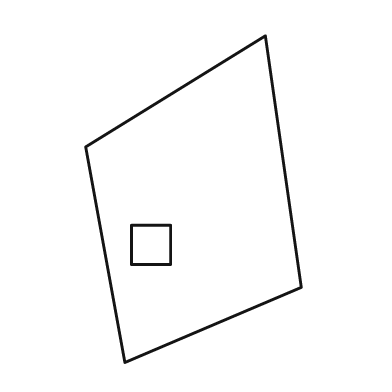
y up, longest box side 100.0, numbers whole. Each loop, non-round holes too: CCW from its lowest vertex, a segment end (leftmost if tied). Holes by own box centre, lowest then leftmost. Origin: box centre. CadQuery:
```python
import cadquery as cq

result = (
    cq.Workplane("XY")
    .moveTo(-21.0, -50.0)
    .lineTo(33.0, -27.0)
    .lineTo(22.0, 50.0)
    .lineTo(-33.0, 16.0)
    .close()
    .moveTo(-19.0, -20.0)
    .lineTo(-7.0, -20.0)
    .lineTo(-7.0, -8.0)
    .lineTo(-19.0, -8.0)
    .close()
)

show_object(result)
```